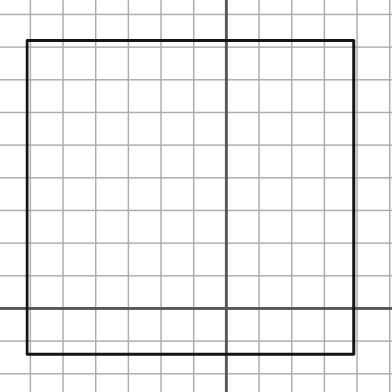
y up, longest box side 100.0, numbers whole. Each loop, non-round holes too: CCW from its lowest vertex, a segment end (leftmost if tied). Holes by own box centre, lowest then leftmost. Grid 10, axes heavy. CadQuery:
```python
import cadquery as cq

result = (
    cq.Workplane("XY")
    .moveTo(-61.0, -14.0)
    .lineTo(39.0, -14.0)
    .lineTo(39.0, 82.0)
    .lineTo(-61.0, 82.0)
    .close()
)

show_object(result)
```